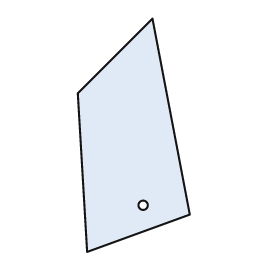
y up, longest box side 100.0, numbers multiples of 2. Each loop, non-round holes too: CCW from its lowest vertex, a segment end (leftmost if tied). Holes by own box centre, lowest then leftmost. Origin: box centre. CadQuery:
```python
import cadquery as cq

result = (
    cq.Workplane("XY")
    .moveTo(-20.0, -50.0)
    .lineTo(24.0, -34.0)
    .lineTo(8.0, 50.0)
    .lineTo(-24.0, 18.0)
    .close()
    .moveTo(4.0, -30.0)
    .circle(2.0)
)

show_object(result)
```